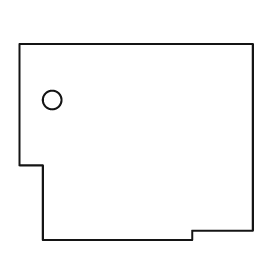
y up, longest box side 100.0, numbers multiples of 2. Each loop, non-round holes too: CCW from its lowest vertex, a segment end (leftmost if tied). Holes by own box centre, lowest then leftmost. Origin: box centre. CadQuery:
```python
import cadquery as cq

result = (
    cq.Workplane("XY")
    .moveTo(-40.0, -42.0)
    .lineTo(24.0, -42.0)
    .lineTo(24.0, -38.0)
    .lineTo(50.0, -38.0)
    .lineTo(50.0, 42.0)
    .lineTo(-50.0, 42.0)
    .lineTo(-50.0, -10.0)
    .lineTo(-40.0, -10.0)
    .close()
    .moveTo(-36.0, 18.0)
    .circle(4.0)
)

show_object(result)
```